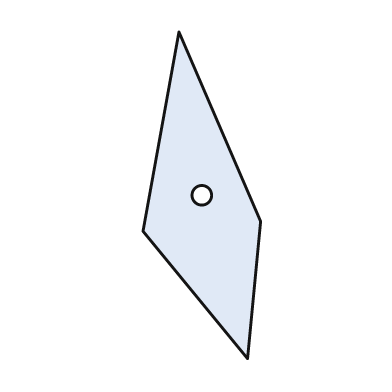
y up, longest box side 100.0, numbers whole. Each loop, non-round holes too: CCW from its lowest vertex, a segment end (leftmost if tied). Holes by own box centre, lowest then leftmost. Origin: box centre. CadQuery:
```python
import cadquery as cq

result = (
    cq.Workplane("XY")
    .moveTo(14.0, -50.0)
    .lineTo(18.0, -8.0)
    .lineTo(-7.0, 50.0)
    .lineTo(-18.0, -11.0)
    .close()
    .moveTo(0.0, 0.0)
    .circle(3.0)
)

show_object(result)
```